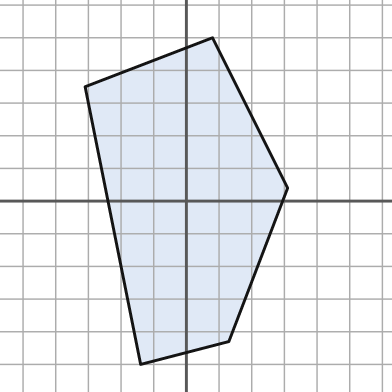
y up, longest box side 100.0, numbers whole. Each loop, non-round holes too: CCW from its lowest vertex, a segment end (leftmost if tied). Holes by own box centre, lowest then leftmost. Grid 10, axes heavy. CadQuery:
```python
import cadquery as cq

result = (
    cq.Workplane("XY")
    .moveTo(-14.0, -50.0)
    .lineTo(13.0, -43.0)
    .lineTo(31.0, 4.0)
    .lineTo(8.0, 50.0)
    .lineTo(-31.0, 35.0)
    .close()
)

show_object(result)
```